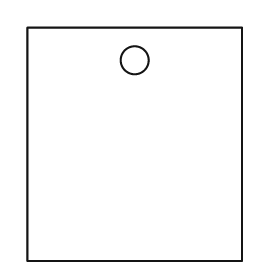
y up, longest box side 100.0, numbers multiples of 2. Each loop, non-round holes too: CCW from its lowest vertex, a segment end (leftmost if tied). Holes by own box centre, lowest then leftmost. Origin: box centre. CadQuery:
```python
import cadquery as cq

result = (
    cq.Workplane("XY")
    .moveTo(-46.0, -50.0)
    .lineTo(46.0, -50.0)
    .lineTo(46.0, 50.0)
    .lineTo(-46.0, 50.0)
    .close()
    .moveTo(0.0, 36.0)
    .circle(6.0)
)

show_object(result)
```